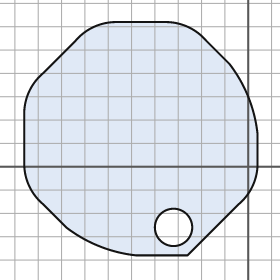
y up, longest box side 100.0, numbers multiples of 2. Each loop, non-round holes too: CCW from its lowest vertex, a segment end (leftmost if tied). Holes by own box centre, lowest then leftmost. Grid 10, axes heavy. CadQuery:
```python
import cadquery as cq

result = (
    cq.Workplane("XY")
    .moveTo(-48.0, -38.0)
    .lineTo(-26.0, -38.0)
    .lineTo(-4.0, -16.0)
    .threePointArc((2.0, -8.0), (4.0, 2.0))
    .lineTo(4.0, 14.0)
    .threePointArc((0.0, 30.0), (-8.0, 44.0))
    .lineTo(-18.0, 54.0)
    .threePointArc((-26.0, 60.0), (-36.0, 62.0))
    .lineTo(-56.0, 62.0)
    .threePointArc((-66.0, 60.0), (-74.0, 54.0))
    .lineTo(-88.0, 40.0)
    .threePointArc((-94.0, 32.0), (-96.0, 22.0))
    .lineTo(-96.0, 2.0)
    .threePointArc((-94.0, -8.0), (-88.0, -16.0))
    .lineTo(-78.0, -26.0)
    .threePointArc((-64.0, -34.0), (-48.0, -38.0))
    .close()
    .moveTo(-32.0, -26.0)
    .circle(8.0)
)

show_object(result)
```